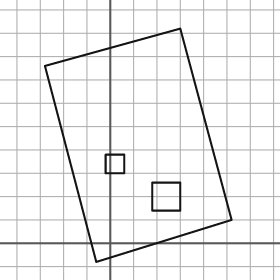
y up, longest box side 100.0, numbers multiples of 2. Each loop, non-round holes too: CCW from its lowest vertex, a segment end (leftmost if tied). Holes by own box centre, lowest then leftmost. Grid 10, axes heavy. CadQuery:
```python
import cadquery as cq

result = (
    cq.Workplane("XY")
    .moveTo(-6.0, -8.0)
    .lineTo(52.0, 10.0)
    .lineTo(30.0, 92.0)
    .lineTo(-28.0, 76.0)
    .close()
    .moveTo(18.0, 14.0)
    .lineTo(30.0, 14.0)
    .lineTo(30.0, 26.0)
    .lineTo(18.0, 26.0)
    .close()
    .moveTo(-2.0, 30.0)
    .lineTo(6.0, 30.0)
    .lineTo(6.0, 38.0)
    .lineTo(-2.0, 38.0)
    .close()
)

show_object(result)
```